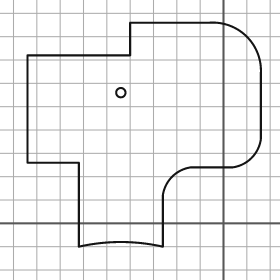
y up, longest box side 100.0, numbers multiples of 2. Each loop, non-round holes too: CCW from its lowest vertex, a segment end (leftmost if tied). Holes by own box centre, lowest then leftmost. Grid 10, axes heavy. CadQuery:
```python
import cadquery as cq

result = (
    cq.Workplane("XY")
    .moveTo(-62.0, -10.0)
    .threePointArc((-44.0, -8.0), (-26.0, -10.0))
    .lineTo(-26.0, 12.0)
    .threePointArc((-22.0, 20.0), (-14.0, 24.0))
    .lineTo(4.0, 24.0)
    .threePointArc((12.0, 28.0), (16.0, 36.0))
    .lineTo(16.0, 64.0)
    .threePointArc((10.0, 80.0), (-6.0, 86.0))
    .lineTo(-40.0, 86.0)
    .lineTo(-40.0, 72.0)
    .lineTo(-84.0, 72.0)
    .lineTo(-84.0, 26.0)
    .lineTo(-62.0, 26.0)
    .close()
    .moveTo(-44.0, 56.0)
    .circle(2.0)
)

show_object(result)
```